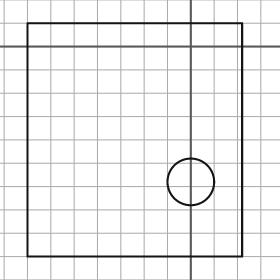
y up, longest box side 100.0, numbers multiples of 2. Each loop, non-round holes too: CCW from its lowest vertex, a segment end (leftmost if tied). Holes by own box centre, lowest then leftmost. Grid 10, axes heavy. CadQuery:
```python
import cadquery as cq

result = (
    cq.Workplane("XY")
    .moveTo(-70.0, -90.0)
    .lineTo(22.0, -90.0)
    .lineTo(22.0, 10.0)
    .lineTo(-70.0, 10.0)
    .close()
    .moveTo(0.0, -58.0)
    .circle(10.0)
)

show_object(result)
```